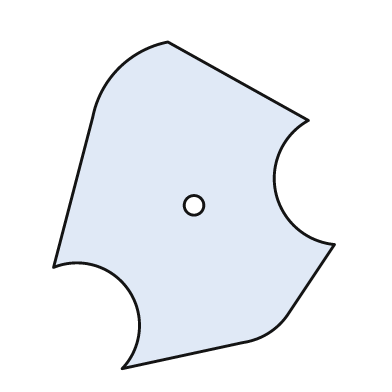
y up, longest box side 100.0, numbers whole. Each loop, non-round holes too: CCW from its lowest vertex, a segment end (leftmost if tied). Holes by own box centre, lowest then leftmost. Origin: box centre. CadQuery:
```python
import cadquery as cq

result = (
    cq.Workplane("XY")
    .moveTo(-22.0, -50.0)
    .lineTo(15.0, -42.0)
    .threePointArc((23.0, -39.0), (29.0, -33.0))
    .lineTo(43.0, -12.0)
    .threePointArc((25.0, 4.0), (35.0, 26.0))
    .lineTo(-8.0, 50.0)
    .threePointArc((-23.0, 42.0), (-31.0, 27.0))
    .lineTo(-43.0, -19.0)
    .threePointArc((-20.0, -26.0), (-22.0, -50.0))
    .close()
    .moveTo(0.0, 0.0)
    .circle(3.0)
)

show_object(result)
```